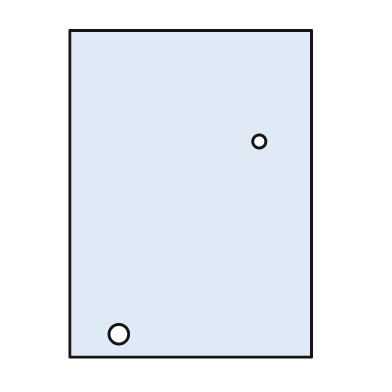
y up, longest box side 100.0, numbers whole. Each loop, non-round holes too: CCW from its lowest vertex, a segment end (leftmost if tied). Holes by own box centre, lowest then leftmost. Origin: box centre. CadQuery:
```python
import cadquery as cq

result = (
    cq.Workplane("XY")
    .moveTo(-37.0, -50.0)
    .lineTo(37.0, -50.0)
    .lineTo(37.0, 50.0)
    .lineTo(-37.0, 50.0)
    .close()
    .moveTo(-22.0, -43.0)
    .circle(3.0)
    .moveTo(21.0, 16.0)
    .circle(2.0)
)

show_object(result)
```